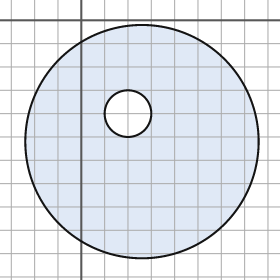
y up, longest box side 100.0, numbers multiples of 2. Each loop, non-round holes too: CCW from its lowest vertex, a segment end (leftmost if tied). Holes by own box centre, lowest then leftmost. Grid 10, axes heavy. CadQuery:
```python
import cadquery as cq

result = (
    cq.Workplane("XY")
    .moveTo(26.0, -52.0)
    .circle(50.0)
    .moveTo(20.0, -40.0)
    .circle(10.0)
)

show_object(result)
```